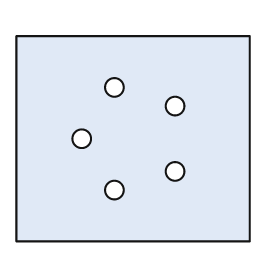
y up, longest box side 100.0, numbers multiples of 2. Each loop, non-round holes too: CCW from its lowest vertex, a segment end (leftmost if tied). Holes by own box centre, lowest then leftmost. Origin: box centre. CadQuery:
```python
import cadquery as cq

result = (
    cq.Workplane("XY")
    .moveTo(-50.0, -44.0)
    .lineTo(50.0, -44.0)
    .lineTo(50.0, 44.0)
    .lineTo(-50.0, 44.0)
    .close()
    .moveTo(-8.0, -22.0)
    .circle(4.0)
    .moveTo(18.0, -14.0)
    .circle(4.0)
    .moveTo(-22.0, 0.0)
    .circle(4.0)
    .moveTo(18.0, 14.0)
    .circle(4.0)
    .moveTo(-8.0, 22.0)
    .circle(4.0)
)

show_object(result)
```